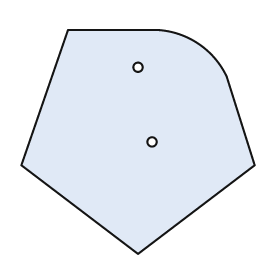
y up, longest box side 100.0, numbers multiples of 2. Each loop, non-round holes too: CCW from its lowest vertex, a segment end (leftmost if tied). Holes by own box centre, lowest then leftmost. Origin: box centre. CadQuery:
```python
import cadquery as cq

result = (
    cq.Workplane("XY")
    .moveTo(0.0, -48.0)
    .lineTo(50.0, -10.0)
    .lineTo(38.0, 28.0)
    .threePointArc((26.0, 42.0), (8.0, 48.0))
    .lineTo(-30.0, 48.0)
    .lineTo(-50.0, -10.0)
    .close()
    .moveTo(6.0, 0.0)
    .circle(2.0)
    .moveTo(0.0, 32.0)
    .circle(2.0)
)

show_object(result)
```